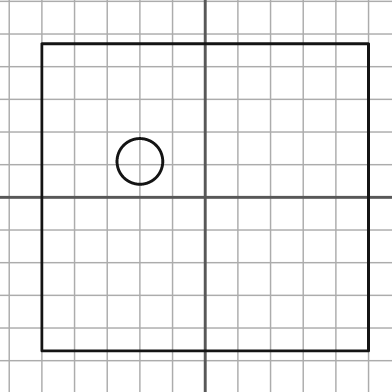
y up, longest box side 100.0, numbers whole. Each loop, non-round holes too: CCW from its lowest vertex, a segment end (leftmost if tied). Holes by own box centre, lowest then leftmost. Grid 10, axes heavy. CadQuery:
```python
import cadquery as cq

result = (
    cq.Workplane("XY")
    .moveTo(-50.0, -47.0)
    .lineTo(50.0, -47.0)
    .lineTo(50.0, 47.0)
    .lineTo(-50.0, 47.0)
    .close()
    .moveTo(-20.0, 11.0)
    .circle(7.0)
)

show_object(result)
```